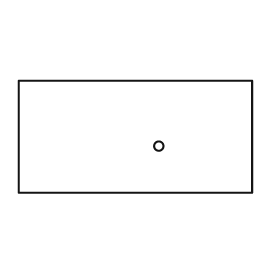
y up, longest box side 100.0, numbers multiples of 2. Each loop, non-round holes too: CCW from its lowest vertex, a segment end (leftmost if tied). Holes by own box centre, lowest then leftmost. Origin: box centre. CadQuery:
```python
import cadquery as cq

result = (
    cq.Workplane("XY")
    .moveTo(-50.0, -24.0)
    .lineTo(50.0, -24.0)
    .lineTo(50.0, 24.0)
    .lineTo(-50.0, 24.0)
    .close()
    .moveTo(10.0, -4.0)
    .circle(2.0)
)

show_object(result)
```